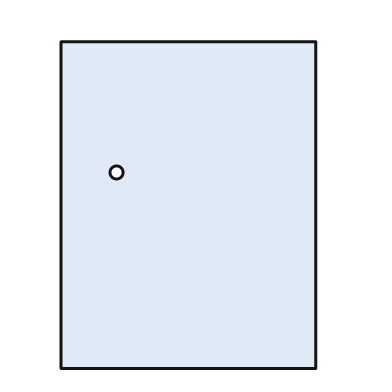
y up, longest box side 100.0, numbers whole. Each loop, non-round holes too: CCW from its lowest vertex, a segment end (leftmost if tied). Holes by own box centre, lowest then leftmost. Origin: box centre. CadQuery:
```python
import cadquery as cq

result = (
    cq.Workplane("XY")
    .moveTo(-39.0, -50.0)
    .lineTo(39.0, -50.0)
    .lineTo(39.0, 50.0)
    .lineTo(-39.0, 50.0)
    .close()
    .moveTo(-22.0, 10.0)
    .circle(2.0)
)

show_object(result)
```